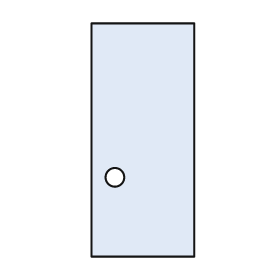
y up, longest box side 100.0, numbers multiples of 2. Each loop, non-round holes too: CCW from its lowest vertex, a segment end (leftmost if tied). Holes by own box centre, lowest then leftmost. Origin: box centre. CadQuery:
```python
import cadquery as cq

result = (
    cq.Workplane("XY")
    .moveTo(-22.0, -50.0)
    .lineTo(22.0, -50.0)
    .lineTo(22.0, 50.0)
    .lineTo(-22.0, 50.0)
    .close()
    .moveTo(-12.0, -16.0)
    .circle(4.0)
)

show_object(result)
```